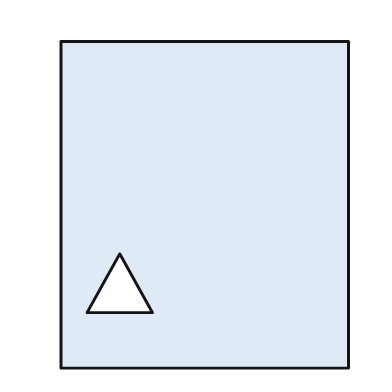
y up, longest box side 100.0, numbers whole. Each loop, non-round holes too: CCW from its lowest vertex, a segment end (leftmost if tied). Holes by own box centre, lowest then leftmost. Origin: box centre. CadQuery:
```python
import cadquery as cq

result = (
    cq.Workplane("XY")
    .moveTo(-44.0, -50.0)
    .lineTo(44.0, -50.0)
    .lineTo(44.0, 50.0)
    .lineTo(-44.0, 50.0)
    .close()
    .moveTo(-36.0, -33.0)
    .lineTo(-16.0, -33.0)
    .lineTo(-26.0, -15.0)
    .close()
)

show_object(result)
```